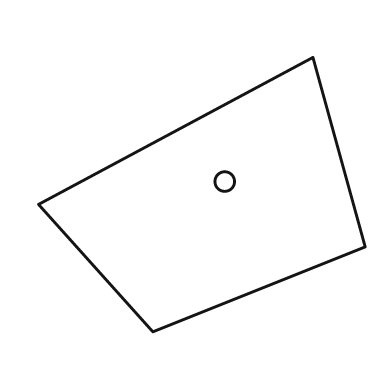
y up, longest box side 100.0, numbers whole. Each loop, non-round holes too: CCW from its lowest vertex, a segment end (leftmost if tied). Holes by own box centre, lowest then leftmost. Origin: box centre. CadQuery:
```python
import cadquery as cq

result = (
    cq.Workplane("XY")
    .moveTo(-15.0, -42.0)
    .lineTo(50.0, -16.0)
    .lineTo(34.0, 42.0)
    .lineTo(-50.0, -3.0)
    .close()
    .moveTo(7.0, 4.0)
    .circle(3.0)
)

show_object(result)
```